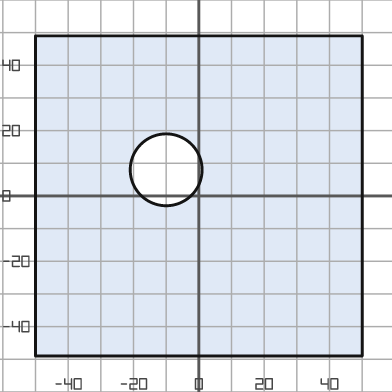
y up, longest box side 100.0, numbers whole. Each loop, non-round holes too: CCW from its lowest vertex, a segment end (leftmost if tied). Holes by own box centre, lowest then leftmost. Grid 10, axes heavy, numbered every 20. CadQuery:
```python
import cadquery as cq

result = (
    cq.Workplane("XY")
    .moveTo(-50.0, -49.0)
    .lineTo(50.0, -49.0)
    .lineTo(50.0, 49.0)
    .lineTo(-50.0, 49.0)
    .close()
    .moveTo(-10.0, 8.0)
    .circle(11.0)
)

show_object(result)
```